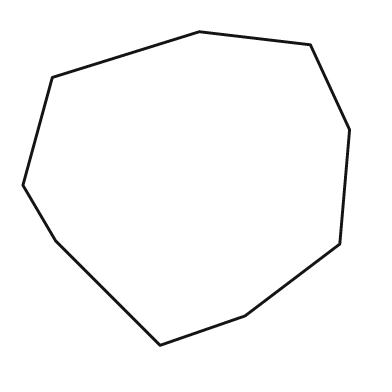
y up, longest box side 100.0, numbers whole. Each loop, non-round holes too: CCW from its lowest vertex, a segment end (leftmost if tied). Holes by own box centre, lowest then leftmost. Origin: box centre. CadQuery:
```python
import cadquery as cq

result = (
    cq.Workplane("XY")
    .moveTo(-8.0, -48.0)
    .lineTo(18.0, -39.0)
    .lineTo(47.0, -17.0)
    .lineTo(50.0, 18.0)
    .lineTo(38.0, 44.0)
    .lineTo(4.0, 48.0)
    .lineTo(-41.0, 34.0)
    .lineTo(-50.0, 1.0)
    .lineTo(-40.0, -16.0)
    .close()
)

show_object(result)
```